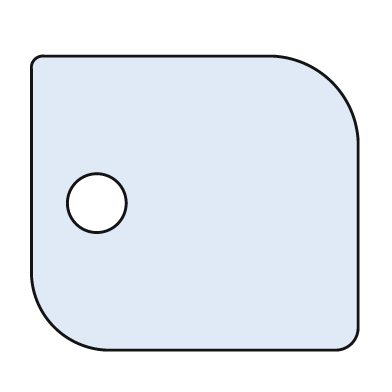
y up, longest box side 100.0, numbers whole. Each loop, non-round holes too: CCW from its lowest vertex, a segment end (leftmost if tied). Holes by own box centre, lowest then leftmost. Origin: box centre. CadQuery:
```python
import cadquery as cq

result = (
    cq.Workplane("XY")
    .moveTo(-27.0, -45.0)
    .lineTo(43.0, -45.0)
    .threePointArc((48.0, -43.0), (50.0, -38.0))
    .lineTo(50.0, 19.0)
    .threePointArc((42.0, 37.0), (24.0, 45.0))
    .lineTo(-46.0, 45.0)
    .threePointArc((-49.0, 44.0), (-50.0, 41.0))
    .lineTo(-50.0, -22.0)
    .threePointArc((-43.0, -38.0), (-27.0, -45.0))
    .close()
    .moveTo(-30.0, 0.0)
    .circle(9.0)
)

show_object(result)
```